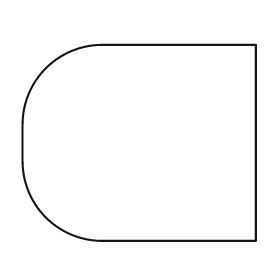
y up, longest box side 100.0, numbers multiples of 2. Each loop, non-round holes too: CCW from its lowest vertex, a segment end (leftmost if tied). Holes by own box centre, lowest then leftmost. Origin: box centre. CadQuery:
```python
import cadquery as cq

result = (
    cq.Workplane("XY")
    .moveTo(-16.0, -42.0)
    .lineTo(50.0, -42.0)
    .lineTo(50.0, 42.0)
    .lineTo(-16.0, 42.0)
    .threePointArc((-40.0, 32.0), (-50.0, 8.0))
    .lineTo(-50.0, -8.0)
    .threePointArc((-40.0, -32.0), (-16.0, -42.0))
    .close()
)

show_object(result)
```